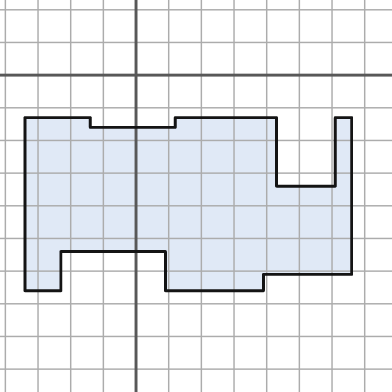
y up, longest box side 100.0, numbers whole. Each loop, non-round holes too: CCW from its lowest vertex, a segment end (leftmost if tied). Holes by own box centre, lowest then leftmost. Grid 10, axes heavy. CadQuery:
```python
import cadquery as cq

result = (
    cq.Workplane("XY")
    .moveTo(-34.0, -66.0)
    .lineTo(-23.0, -66.0)
    .lineTo(-23.0, -54.0)
    .lineTo(9.0, -54.0)
    .lineTo(9.0, -66.0)
    .lineTo(39.0, -66.0)
    .lineTo(39.0, -61.0)
    .lineTo(66.0, -61.0)
    .lineTo(66.0, -13.0)
    .lineTo(61.0, -13.0)
    .lineTo(61.0, -34.0)
    .lineTo(43.0, -34.0)
    .lineTo(43.0, -13.0)
    .lineTo(12.0, -13.0)
    .lineTo(12.0, -16.0)
    .lineTo(-14.0, -16.0)
    .lineTo(-14.0, -13.0)
    .lineTo(-34.0, -13.0)
    .close()
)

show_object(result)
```